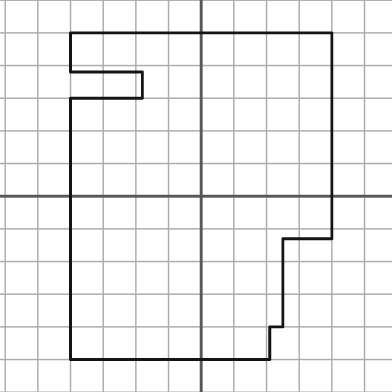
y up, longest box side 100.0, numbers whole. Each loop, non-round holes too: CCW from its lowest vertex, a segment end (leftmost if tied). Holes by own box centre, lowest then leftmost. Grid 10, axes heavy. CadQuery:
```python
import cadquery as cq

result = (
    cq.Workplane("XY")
    .moveTo(-40.0, -50.0)
    .lineTo(21.0, -50.0)
    .lineTo(21.0, -40.0)
    .lineTo(25.0, -40.0)
    .lineTo(25.0, -13.0)
    .lineTo(40.0, -13.0)
    .lineTo(40.0, 50.0)
    .lineTo(-40.0, 50.0)
    .lineTo(-40.0, 38.0)
    .lineTo(-18.0, 38.0)
    .lineTo(-18.0, 30.0)
    .lineTo(-40.0, 30.0)
    .close()
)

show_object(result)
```